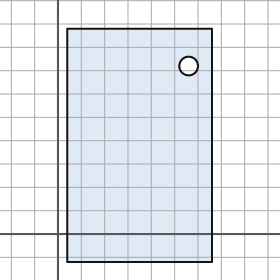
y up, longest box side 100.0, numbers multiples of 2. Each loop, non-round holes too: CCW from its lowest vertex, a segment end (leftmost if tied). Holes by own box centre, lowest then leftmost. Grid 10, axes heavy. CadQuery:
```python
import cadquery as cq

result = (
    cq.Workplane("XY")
    .moveTo(4.0, -12.0)
    .lineTo(66.0, -12.0)
    .lineTo(66.0, 88.0)
    .lineTo(4.0, 88.0)
    .close()
    .moveTo(56.0, 72.0)
    .circle(4.0)
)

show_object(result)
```